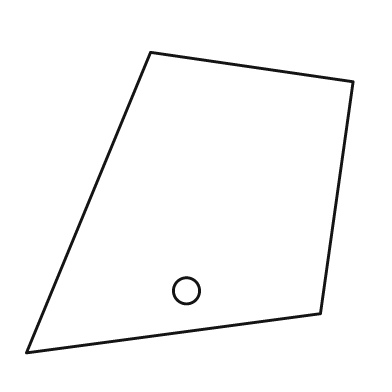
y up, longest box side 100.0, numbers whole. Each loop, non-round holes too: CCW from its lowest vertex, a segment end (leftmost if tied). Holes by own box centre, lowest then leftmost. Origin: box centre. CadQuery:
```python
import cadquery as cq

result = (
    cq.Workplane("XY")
    .moveTo(-50.0, -46.0)
    .lineTo(40.0, -34.0)
    .lineTo(50.0, 37.0)
    .lineTo(-12.0, 46.0)
    .close()
    .moveTo(-1.0, -27.0)
    .circle(4.0)
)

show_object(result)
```